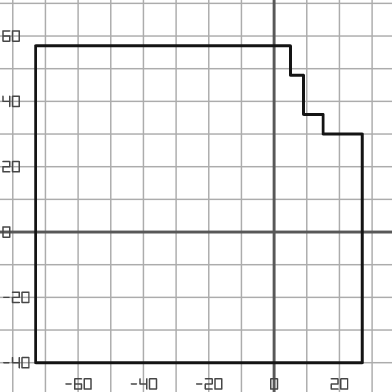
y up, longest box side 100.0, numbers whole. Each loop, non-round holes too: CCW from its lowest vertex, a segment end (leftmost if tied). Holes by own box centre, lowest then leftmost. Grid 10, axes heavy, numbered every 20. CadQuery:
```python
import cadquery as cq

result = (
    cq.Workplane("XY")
    .moveTo(-73.0, -40.0)
    .lineTo(27.0, -40.0)
    .lineTo(27.0, 30.0)
    .lineTo(15.0, 30.0)
    .lineTo(15.0, 36.0)
    .lineTo(9.0, 36.0)
    .lineTo(9.0, 48.0)
    .lineTo(5.0, 48.0)
    .lineTo(5.0, 57.0)
    .lineTo(-73.0, 57.0)
    .close()
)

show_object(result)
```